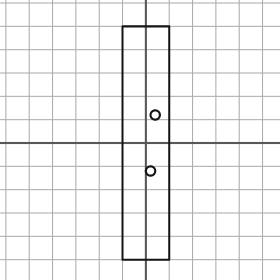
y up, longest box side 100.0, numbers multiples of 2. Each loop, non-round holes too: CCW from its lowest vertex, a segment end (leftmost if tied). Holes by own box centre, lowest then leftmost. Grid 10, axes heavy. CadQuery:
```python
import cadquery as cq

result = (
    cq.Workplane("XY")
    .moveTo(-10.0, -50.0)
    .lineTo(10.0, -50.0)
    .lineTo(10.0, 50.0)
    .lineTo(-10.0, 50.0)
    .close()
    .moveTo(2.0, -12.0)
    .circle(2.0)
    .moveTo(4.0, 12.0)
    .circle(2.0)
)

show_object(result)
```